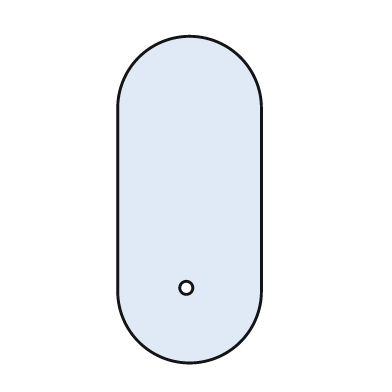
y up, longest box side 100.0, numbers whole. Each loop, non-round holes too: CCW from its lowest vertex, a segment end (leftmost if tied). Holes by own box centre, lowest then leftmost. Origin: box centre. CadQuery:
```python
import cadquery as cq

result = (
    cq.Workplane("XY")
    .moveTo(-22.0, -28.0)
    .threePointArc((0.0, -50.0), (22.0, -28.0))
    .lineTo(22.0, 28.0)
    .threePointArc((0.0, 50.0), (-22.0, 28.0))
    .close()
    .moveTo(-1.0, -27.0)
    .circle(2.0)
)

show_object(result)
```